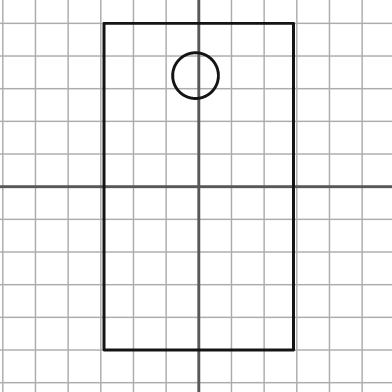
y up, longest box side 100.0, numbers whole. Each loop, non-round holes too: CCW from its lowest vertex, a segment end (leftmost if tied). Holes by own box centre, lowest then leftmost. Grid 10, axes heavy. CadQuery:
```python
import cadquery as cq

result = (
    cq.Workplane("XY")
    .moveTo(-29.0, -50.0)
    .lineTo(29.0, -50.0)
    .lineTo(29.0, 50.0)
    .lineTo(-29.0, 50.0)
    .close()
    .moveTo(-1.0, 34.0)
    .circle(7.0)
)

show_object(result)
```